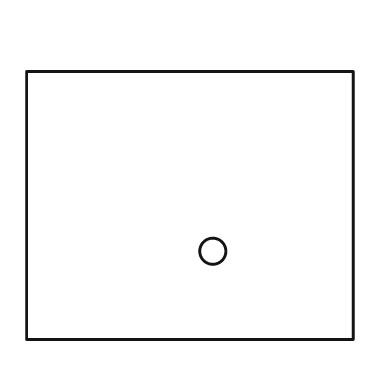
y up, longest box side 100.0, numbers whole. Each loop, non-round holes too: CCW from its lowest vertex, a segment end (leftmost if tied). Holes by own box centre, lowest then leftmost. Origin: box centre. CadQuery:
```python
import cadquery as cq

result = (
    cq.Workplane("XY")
    .moveTo(-50.0, -41.0)
    .lineTo(50.0, -41.0)
    .lineTo(50.0, 41.0)
    .lineTo(-50.0, 41.0)
    .close()
    .moveTo(7.0, -14.0)
    .circle(4.0)
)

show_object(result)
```